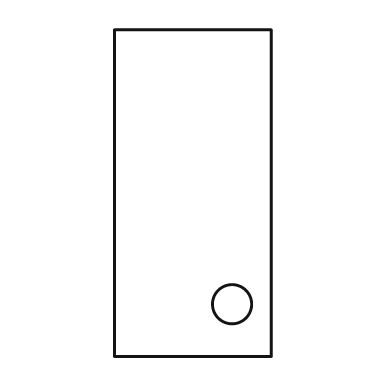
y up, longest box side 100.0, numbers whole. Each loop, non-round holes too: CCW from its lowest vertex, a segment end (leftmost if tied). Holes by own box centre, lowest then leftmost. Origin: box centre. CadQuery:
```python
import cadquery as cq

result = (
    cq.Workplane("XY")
    .moveTo(-24.0, -50.0)
    .lineTo(24.0, -50.0)
    .lineTo(24.0, 50.0)
    .lineTo(-24.0, 50.0)
    .close()
    .moveTo(12.0, -34.0)
    .circle(6.0)
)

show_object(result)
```